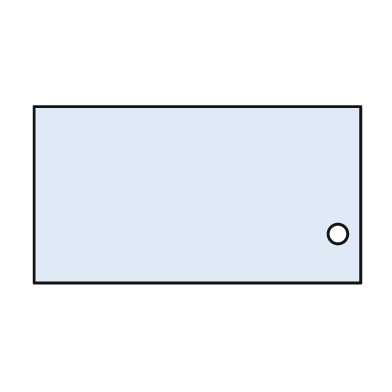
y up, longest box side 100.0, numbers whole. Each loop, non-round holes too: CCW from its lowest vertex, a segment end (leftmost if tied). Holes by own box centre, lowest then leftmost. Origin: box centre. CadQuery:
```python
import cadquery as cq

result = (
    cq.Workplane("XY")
    .moveTo(-50.0, -27.0)
    .lineTo(50.0, -27.0)
    .lineTo(50.0, 27.0)
    .lineTo(-50.0, 27.0)
    .close()
    .moveTo(43.0, -12.0)
    .circle(3.0)
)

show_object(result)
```